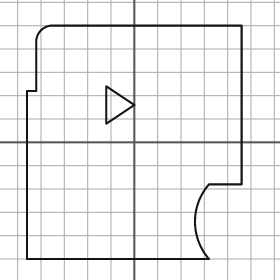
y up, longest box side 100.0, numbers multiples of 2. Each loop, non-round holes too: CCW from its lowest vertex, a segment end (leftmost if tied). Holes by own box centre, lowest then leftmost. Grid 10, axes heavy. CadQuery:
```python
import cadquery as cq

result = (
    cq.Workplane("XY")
    .moveTo(-46.0, -50.0)
    .lineTo(32.0, -50.0)
    .threePointArc((26.0, -34.0), (32.0, -18.0))
    .lineTo(46.0, -18.0)
    .lineTo(46.0, 50.0)
    .lineTo(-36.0, 50.0)
    .threePointArc((-40.0, 48.0), (-42.0, 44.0))
    .lineTo(-42.0, 22.0)
    .lineTo(-46.0, 22.0)
    .close()
    .moveTo(-12.0, 8.0)
    .lineTo(0.0, 16.0)
    .lineTo(-12.0, 24.0)
    .close()
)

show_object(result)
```